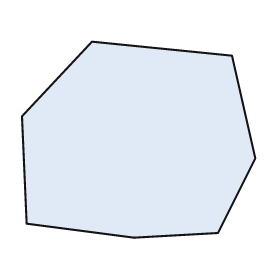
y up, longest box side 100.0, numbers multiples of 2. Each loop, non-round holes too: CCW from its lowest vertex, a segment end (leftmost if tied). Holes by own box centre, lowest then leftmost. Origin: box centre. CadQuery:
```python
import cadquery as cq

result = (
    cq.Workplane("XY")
    .moveTo(-2.0, -42.0)
    .lineTo(34.0, -40.0)
    .lineTo(50.0, -8.0)
    .lineTo(40.0, 36.0)
    .lineTo(-20.0, 42.0)
    .lineTo(-50.0, 10.0)
    .lineTo(-48.0, -36.0)
    .close()
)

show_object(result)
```